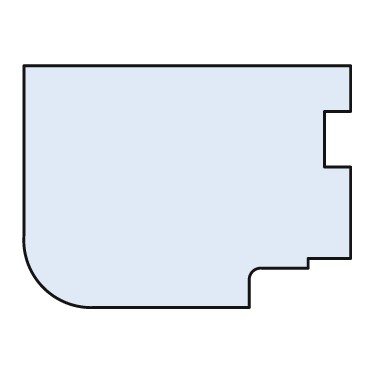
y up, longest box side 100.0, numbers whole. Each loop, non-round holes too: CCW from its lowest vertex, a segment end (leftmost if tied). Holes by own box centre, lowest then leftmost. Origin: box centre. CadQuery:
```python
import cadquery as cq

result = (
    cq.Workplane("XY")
    .moveTo(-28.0, -37.0)
    .lineTo(19.0, -37.0)
    .lineTo(19.0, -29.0)
    .threePointArc((20.0, -26.0), (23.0, -25.0))
    .lineTo(37.0, -25.0)
    .lineTo(37.0, -22.0)
    .lineTo(50.0, -22.0)
    .lineTo(50.0, 6.0)
    .lineTo(42.0, 6.0)
    .lineTo(42.0, 23.0)
    .lineTo(50.0, 23.0)
    .lineTo(50.0, 37.0)
    .lineTo(-50.0, 37.0)
    .lineTo(-50.0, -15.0)
    .threePointArc((-44.0, -31.0), (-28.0, -37.0))
    .close()
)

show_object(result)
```